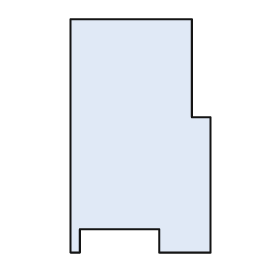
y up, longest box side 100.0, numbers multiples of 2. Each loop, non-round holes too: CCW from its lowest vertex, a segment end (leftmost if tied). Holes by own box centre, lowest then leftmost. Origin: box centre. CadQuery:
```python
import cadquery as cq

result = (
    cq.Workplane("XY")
    .moveTo(-30.0, -50.0)
    .lineTo(-26.0, -50.0)
    .lineTo(-26.0, -40.0)
    .lineTo(8.0, -40.0)
    .lineTo(8.0, -50.0)
    .lineTo(30.0, -50.0)
    .lineTo(30.0, 8.0)
    .lineTo(22.0, 8.0)
    .lineTo(22.0, 50.0)
    .lineTo(-30.0, 50.0)
    .close()
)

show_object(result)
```